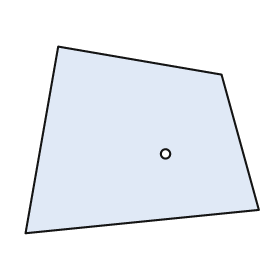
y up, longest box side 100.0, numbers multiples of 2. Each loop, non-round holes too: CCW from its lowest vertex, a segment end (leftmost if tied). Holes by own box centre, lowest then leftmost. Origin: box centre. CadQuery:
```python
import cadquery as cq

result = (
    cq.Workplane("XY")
    .moveTo(-50.0, -40.0)
    .lineTo(50.0, -30.0)
    .lineTo(34.0, 28.0)
    .lineTo(-36.0, 40.0)
    .close()
    .moveTo(10.0, -6.0)
    .circle(2.0)
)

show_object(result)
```